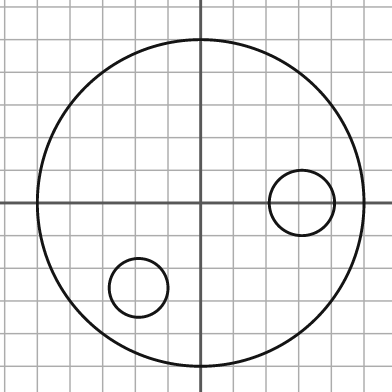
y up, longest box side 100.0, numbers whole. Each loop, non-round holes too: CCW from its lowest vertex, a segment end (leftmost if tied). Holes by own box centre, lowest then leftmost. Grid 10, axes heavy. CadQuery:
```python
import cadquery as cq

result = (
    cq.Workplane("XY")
    .moveTo(0.0, 0.0)
    .circle(50.0)
    .moveTo(-19.0, -26.0)
    .circle(9.0)
    .moveTo(31.0, 0.0)
    .circle(10.0)
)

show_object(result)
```